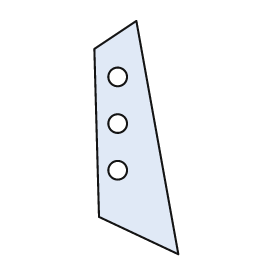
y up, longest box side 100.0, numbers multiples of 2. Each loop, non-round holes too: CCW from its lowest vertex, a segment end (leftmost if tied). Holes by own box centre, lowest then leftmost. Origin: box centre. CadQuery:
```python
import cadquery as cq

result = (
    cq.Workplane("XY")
    .moveTo(18.0, -50.0)
    .lineTo(0.0, 50.0)
    .lineTo(-18.0, 38.0)
    .lineTo(-16.0, -34.0)
    .close()
    .moveTo(-8.0, -14.0)
    .circle(4.0)
    .moveTo(-8.0, 6.0)
    .circle(4.0)
    .moveTo(-8.0, 26.0)
    .circle(4.0)
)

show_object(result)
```